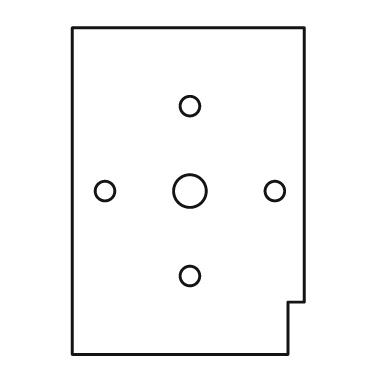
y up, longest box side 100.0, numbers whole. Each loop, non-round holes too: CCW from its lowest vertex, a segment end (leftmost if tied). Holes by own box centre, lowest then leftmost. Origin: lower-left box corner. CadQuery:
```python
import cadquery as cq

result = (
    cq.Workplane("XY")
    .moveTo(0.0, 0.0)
    .lineTo(66.0, 0.0)
    .lineTo(66.0, 16.0)
    .lineTo(71.0, 16.0)
    .lineTo(71.0, 100.0)
    .lineTo(0.0, 100.0)
    .close()
    .moveTo(36.0, 24.0)
    .circle(3.0)
    .moveTo(10.0, 50.0)
    .circle(3.0)
    .moveTo(36.0, 50.0)
    .circle(5.0)
    .moveTo(62.0, 50.0)
    .circle(3.0)
    .moveTo(36.0, 76.0)
    .circle(3.0)
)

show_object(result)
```